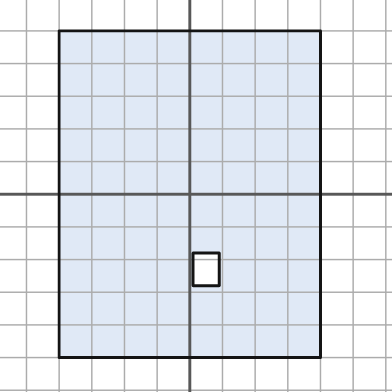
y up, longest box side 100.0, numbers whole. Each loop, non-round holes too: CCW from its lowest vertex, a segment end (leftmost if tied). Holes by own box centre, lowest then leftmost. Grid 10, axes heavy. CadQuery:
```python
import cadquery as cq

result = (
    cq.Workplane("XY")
    .moveTo(-40.0, -50.0)
    .lineTo(40.0, -50.0)
    .lineTo(40.0, 50.0)
    .lineTo(-40.0, 50.0)
    .close()
    .moveTo(1.0, -28.0)
    .lineTo(9.0, -28.0)
    .lineTo(9.0, -18.0)
    .lineTo(1.0, -18.0)
    .close()
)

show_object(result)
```